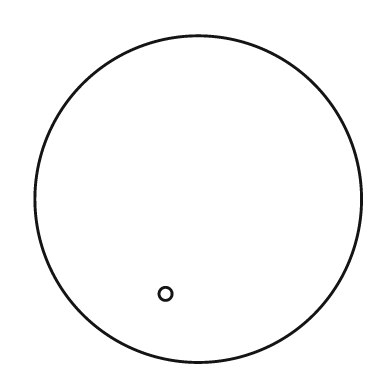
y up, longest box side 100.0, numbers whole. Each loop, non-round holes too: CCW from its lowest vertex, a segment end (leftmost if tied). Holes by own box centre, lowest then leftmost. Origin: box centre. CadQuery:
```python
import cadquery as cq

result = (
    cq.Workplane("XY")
    .moveTo(0.0, 0.0)
    .circle(50.0)
    .moveTo(-10.0, -29.0)
    .circle(2.0)
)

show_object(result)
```